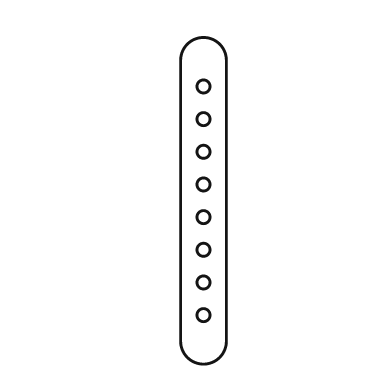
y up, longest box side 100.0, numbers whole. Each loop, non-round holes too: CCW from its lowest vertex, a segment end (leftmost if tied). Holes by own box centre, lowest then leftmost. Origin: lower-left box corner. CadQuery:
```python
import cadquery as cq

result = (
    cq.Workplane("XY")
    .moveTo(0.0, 7.0)
    .threePointArc((7.0, 0.0), (14.0, 7.0))
    .lineTo(14.0, 93.0)
    .threePointArc((7.0, 100.0), (0.0, 93.0))
    .close()
    .moveTo(7.0, 15.0)
    .circle(2.0)
    .moveTo(7.0, 25.0)
    .circle(2.0)
    .moveTo(7.0, 35.0)
    .circle(2.0)
    .moveTo(7.0, 45.0)
    .circle(2.0)
    .moveTo(7.0, 55.0)
    .circle(2.0)
    .moveTo(7.0, 65.0)
    .circle(2.0)
    .moveTo(7.0, 75.0)
    .circle(2.0)
    .moveTo(7.0, 85.0)
    .circle(2.0)
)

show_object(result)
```